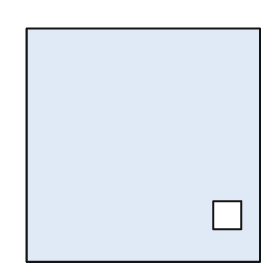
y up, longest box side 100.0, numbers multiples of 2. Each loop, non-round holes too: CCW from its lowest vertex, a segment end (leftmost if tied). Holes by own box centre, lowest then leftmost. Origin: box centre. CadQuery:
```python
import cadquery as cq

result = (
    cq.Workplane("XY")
    .moveTo(-50.0, -50.0)
    .lineTo(50.0, -50.0)
    .lineTo(50.0, 50.0)
    .lineTo(-50.0, 50.0)
    .close()
    .moveTo(30.0, -36.0)
    .lineTo(42.0, -36.0)
    .lineTo(42.0, -24.0)
    .lineTo(30.0, -24.0)
    .close()
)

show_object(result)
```